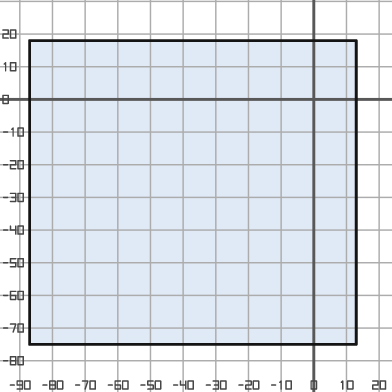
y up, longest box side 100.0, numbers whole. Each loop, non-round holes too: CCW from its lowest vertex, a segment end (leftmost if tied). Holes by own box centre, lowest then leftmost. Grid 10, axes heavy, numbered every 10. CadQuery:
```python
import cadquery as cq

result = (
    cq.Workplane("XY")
    .moveTo(-87.0, -75.0)
    .lineTo(13.0, -75.0)
    .lineTo(13.0, 18.0)
    .lineTo(-87.0, 18.0)
    .close()
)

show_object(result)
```